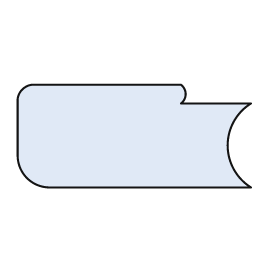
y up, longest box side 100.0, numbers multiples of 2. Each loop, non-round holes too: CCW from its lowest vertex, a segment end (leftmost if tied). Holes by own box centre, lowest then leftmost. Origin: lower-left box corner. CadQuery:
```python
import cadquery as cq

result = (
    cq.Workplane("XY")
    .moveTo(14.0, 0.0)
    .lineTo(100.0, 0.0)
    .threePointArc((90.0, 18.0), (100.0, 36.0))
    .lineTo(70.0, 36.0)
    .threePointArc((72.0, 40.0), (70.0, 44.0))
    .lineTo(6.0, 44.0)
    .threePointArc((2.0, 42.0), (0.0, 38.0))
    .lineTo(0.0, 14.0)
    .threePointArc((4.0, 4.0), (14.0, 0.0))
    .close()
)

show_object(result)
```